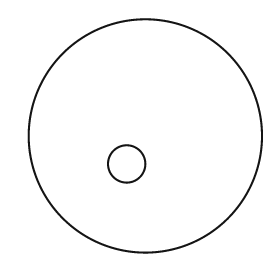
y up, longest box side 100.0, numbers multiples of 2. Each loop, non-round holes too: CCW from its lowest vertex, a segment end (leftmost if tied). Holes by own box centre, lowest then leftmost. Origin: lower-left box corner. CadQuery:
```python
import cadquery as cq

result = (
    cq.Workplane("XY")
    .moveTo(50.0, 50.0)
    .circle(50.0)
    .moveTo(42.0, 38.0)
    .circle(8.0)
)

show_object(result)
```